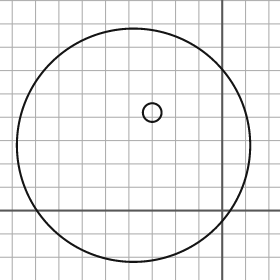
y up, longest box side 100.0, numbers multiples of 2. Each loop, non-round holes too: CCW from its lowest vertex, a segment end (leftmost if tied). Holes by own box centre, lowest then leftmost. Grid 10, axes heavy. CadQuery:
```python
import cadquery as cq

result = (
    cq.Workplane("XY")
    .moveTo(-38.0, 28.0)
    .circle(50.0)
    .moveTo(-30.0, 42.0)
    .circle(4.0)
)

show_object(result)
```